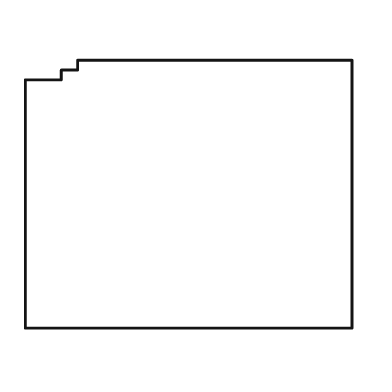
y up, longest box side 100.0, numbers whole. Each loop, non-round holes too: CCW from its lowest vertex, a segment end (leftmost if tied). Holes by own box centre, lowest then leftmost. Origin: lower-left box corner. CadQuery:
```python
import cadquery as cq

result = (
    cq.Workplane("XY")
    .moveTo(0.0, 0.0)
    .lineTo(100.0, 0.0)
    .lineTo(100.0, 82.0)
    .lineTo(16.0, 82.0)
    .lineTo(16.0, 79.0)
    .lineTo(11.0, 79.0)
    .lineTo(11.0, 76.0)
    .lineTo(0.0, 76.0)
    .close()
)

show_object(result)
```